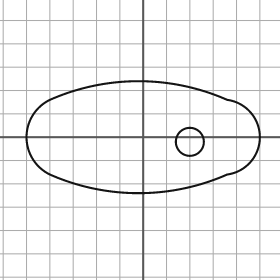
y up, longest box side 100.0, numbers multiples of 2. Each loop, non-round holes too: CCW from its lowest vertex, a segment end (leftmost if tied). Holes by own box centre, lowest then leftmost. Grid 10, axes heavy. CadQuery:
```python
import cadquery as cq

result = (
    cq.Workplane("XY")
    .moveTo(-40.0, -16.0)
    .threePointArc((-2.0, -24.0), (36.0, -16.0))
    .threePointArc((50.0, 0.0), (36.0, 16.0))
    .threePointArc((-2.0, 24.0), (-40.0, 16.0))
    .threePointArc((-50.0, 0.0), (-40.0, -16.0))
    .close()
    .moveTo(20.0, -2.0)
    .circle(6.0)
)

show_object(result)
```